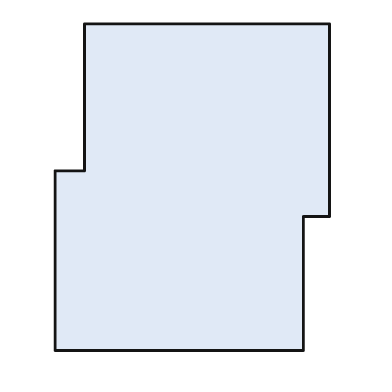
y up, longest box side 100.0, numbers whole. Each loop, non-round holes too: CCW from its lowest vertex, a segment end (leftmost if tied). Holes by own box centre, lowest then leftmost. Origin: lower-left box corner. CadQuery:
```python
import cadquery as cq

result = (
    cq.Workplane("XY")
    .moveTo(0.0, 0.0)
    .lineTo(76.0, 0.0)
    .lineTo(76.0, 41.0)
    .lineTo(84.0, 41.0)
    .lineTo(84.0, 100.0)
    .lineTo(9.0, 100.0)
    .lineTo(9.0, 55.0)
    .lineTo(0.0, 55.0)
    .close()
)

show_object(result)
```